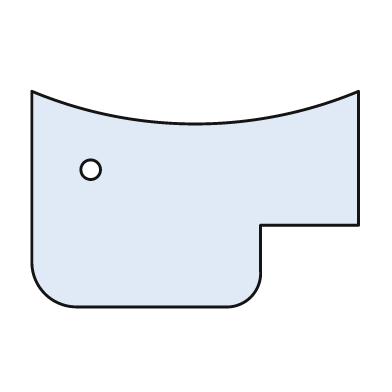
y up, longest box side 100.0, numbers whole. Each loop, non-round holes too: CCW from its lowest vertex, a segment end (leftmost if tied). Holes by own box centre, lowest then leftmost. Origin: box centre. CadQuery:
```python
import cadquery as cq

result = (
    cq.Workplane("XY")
    .moveTo(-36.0, -33.0)
    .lineTo(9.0, -33.0)
    .threePointArc((17.0, -30.0), (20.0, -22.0))
    .lineTo(20.0, -8.0)
    .lineTo(50.0, -8.0)
    .lineTo(50.0, 33.0)
    .threePointArc((0.0, 23.0), (-50.0, 33.0))
    .lineTo(-50.0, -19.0)
    .threePointArc((-46.0, -29.0), (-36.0, -33.0))
    .close()
    .moveTo(-32.0, 9.0)
    .circle(3.0)
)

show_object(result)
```